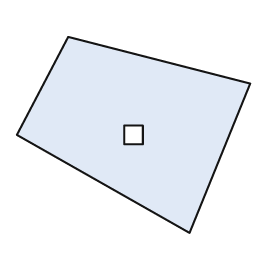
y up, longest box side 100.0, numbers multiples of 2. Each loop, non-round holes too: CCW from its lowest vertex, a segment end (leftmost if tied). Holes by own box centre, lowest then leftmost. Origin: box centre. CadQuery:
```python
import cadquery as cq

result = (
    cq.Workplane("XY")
    .moveTo(24.0, -42.0)
    .lineTo(50.0, 22.0)
    .lineTo(-28.0, 42.0)
    .lineTo(-50.0, 0.0)
    .close()
    .moveTo(-4.0, -4.0)
    .lineTo(4.0, -4.0)
    .lineTo(4.0, 4.0)
    .lineTo(-4.0, 4.0)
    .close()
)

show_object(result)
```